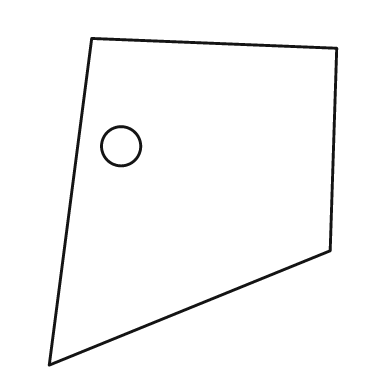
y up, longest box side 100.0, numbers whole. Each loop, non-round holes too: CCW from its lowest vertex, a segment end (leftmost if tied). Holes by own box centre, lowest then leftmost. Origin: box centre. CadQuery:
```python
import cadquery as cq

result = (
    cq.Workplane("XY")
    .moveTo(-44.0, -50.0)
    .lineTo(42.0, -15.0)
    .lineTo(44.0, 47.0)
    .lineTo(-31.0, 50.0)
    .close()
    .moveTo(-22.0, 17.0)
    .circle(6.0)
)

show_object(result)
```